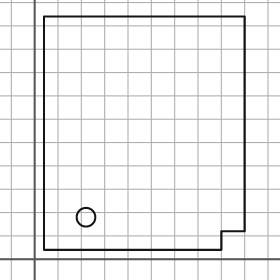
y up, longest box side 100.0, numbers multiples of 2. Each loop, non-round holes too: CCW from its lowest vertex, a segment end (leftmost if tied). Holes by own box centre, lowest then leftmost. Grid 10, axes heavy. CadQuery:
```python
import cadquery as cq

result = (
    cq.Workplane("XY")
    .moveTo(4.0, 4.0)
    .lineTo(80.0, 4.0)
    .lineTo(80.0, 12.0)
    .lineTo(90.0, 12.0)
    .lineTo(90.0, 104.0)
    .lineTo(4.0, 104.0)
    .close()
    .moveTo(22.0, 18.0)
    .circle(4.0)
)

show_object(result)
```